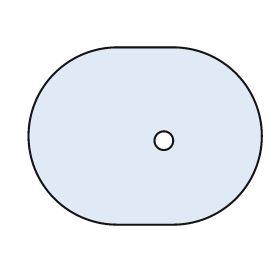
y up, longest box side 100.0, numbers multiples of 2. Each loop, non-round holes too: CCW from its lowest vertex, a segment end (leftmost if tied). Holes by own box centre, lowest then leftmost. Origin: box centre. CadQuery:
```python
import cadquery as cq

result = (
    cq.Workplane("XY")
    .moveTo(-12.0, -38.0)
    .lineTo(12.0, -38.0)
    .threePointArc((50.0, 0.0), (12.0, 38.0))
    .lineTo(-12.0, 38.0)
    .threePointArc((-50.0, 0.0), (-12.0, -38.0))
    .close()
    .moveTo(8.0, -2.0)
    .circle(4.0)
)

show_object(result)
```